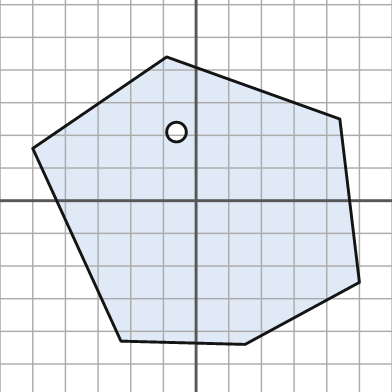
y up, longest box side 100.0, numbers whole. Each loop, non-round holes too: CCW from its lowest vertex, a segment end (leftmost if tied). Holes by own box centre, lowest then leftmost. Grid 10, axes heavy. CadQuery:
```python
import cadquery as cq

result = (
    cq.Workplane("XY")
    .moveTo(15.0, -44.0)
    .lineTo(50.0, -25.0)
    .lineTo(44.0, 25.0)
    .lineTo(-9.0, 44.0)
    .lineTo(-50.0, 16.0)
    .lineTo(-23.0, -43.0)
    .close()
    .moveTo(-6.0, 21.0)
    .circle(3.0)
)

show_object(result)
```